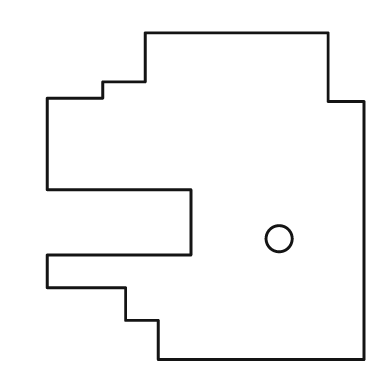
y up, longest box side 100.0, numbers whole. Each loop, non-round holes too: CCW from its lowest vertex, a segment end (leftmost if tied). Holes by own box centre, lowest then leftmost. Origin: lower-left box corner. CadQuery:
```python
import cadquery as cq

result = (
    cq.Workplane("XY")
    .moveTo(34.0, 0.0)
    .lineTo(97.0, 0.0)
    .lineTo(97.0, 79.0)
    .lineTo(86.0, 79.0)
    .lineTo(86.0, 100.0)
    .lineTo(30.0, 100.0)
    .lineTo(30.0, 85.0)
    .lineTo(17.0, 85.0)
    .lineTo(17.0, 80.0)
    .lineTo(0.0, 80.0)
    .lineTo(0.0, 52.0)
    .lineTo(44.0, 52.0)
    .lineTo(44.0, 32.0)
    .lineTo(0.0, 32.0)
    .lineTo(0.0, 22.0)
    .lineTo(24.0, 22.0)
    .lineTo(24.0, 12.0)
    .lineTo(34.0, 12.0)
    .close()
    .moveTo(71.0, 37.0)
    .circle(4.0)
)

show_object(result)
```